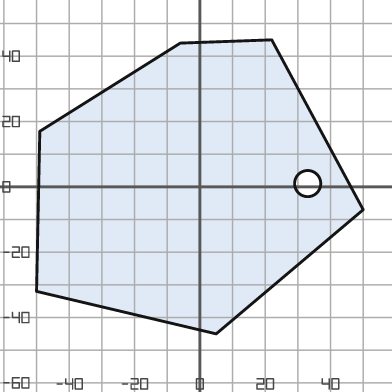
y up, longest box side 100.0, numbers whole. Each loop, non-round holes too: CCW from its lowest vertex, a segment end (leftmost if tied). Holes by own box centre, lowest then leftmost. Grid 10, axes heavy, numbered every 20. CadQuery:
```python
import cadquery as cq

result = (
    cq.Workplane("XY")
    .moveTo(5.0, -45.0)
    .lineTo(50.0, -7.0)
    .lineTo(22.0, 45.0)
    .lineTo(-6.0, 44.0)
    .lineTo(-49.0, 17.0)
    .lineTo(-50.0, -32.0)
    .close()
    .moveTo(33.0, 1.0)
    .circle(4.0)
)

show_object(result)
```